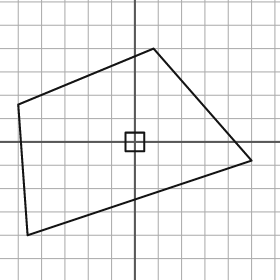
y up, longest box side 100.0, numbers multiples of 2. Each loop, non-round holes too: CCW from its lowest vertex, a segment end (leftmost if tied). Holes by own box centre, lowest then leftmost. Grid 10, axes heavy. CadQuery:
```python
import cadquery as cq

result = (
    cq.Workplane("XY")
    .moveTo(-46.0, -40.0)
    .lineTo(50.0, -8.0)
    .lineTo(8.0, 40.0)
    .lineTo(-50.0, 16.0)
    .close()
    .moveTo(-4.0, -4.0)
    .lineTo(4.0, -4.0)
    .lineTo(4.0, 4.0)
    .lineTo(-4.0, 4.0)
    .close()
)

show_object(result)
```